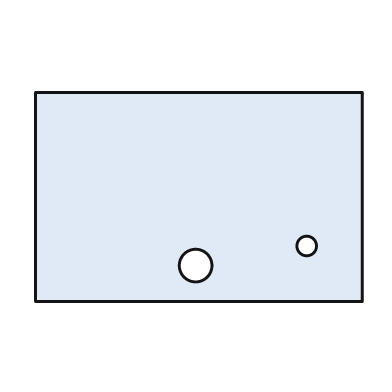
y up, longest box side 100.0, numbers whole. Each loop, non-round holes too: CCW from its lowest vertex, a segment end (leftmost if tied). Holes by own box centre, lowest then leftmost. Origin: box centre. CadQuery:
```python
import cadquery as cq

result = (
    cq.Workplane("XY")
    .moveTo(-50.0, -32.0)
    .lineTo(50.0, -32.0)
    .lineTo(50.0, 32.0)
    .lineTo(-50.0, 32.0)
    .close()
    .moveTo(-1.0, -21.0)
    .circle(5.0)
    .moveTo(33.0, -15.0)
    .circle(3.0)
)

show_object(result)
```